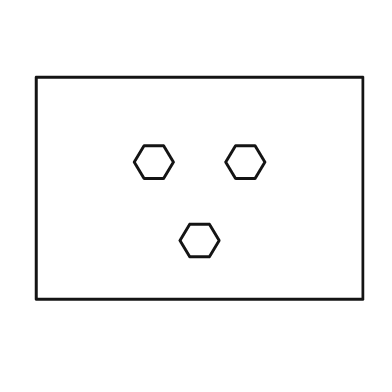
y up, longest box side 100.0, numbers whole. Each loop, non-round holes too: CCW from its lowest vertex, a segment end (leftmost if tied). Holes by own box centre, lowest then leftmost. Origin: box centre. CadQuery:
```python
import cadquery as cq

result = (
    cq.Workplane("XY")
    .moveTo(-50.0, -34.0)
    .lineTo(50.0, -34.0)
    .lineTo(50.0, 34.0)
    .lineTo(-50.0, 34.0)
    .close()
    .moveTo(-3.0, -21.0)
    .lineTo(3.0, -21.0)
    .lineTo(6.0, -16.0)
    .lineTo(3.0, -11.0)
    .lineTo(-3.0, -11.0)
    .lineTo(-6.0, -16.0)
    .close()
    .moveTo(-17.0, 3.0)
    .lineTo(-11.0, 3.0)
    .lineTo(-8.0, 8.0)
    .lineTo(-11.0, 13.0)
    .lineTo(-17.0, 13.0)
    .lineTo(-20.0, 8.0)
    .close()
    .moveTo(11.0, 3.0)
    .lineTo(17.0, 3.0)
    .lineTo(20.0, 8.0)
    .lineTo(17.0, 13.0)
    .lineTo(11.0, 13.0)
    .lineTo(8.0, 8.0)
    .close()
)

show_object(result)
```